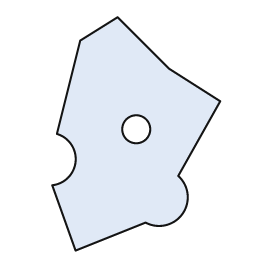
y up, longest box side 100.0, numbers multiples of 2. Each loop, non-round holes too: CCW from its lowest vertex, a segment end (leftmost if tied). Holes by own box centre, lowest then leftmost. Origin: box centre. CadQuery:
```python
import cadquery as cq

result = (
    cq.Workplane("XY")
    .moveTo(-26.0, -50.0)
    .lineTo(4.0, -38.0)
    .threePointArc((20.0, -34.0), (18.0, -18.0))
    .lineTo(36.0, 14.0)
    .lineTo(14.0, 28.0)
    .lineTo(-8.0, 50.0)
    .lineTo(-24.0, 40.0)
    .lineTo(-34.0, 0.0)
    .threePointArc((-26.0, -12.0), (-36.0, -22.0))
    .close()
    .moveTo(0.0, 2.0)
    .circle(6.0)
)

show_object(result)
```